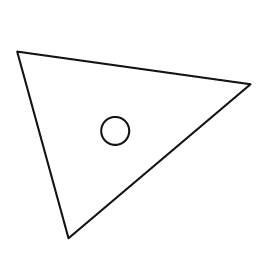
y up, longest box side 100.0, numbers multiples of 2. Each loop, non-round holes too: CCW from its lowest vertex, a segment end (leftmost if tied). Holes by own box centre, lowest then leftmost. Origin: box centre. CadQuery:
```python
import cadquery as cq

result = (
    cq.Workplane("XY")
    .moveTo(-28.0, -40.0)
    .lineTo(50.0, 26.0)
    .lineTo(-50.0, 40.0)
    .close()
    .moveTo(-8.0, 6.0)
    .circle(6.0)
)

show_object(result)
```